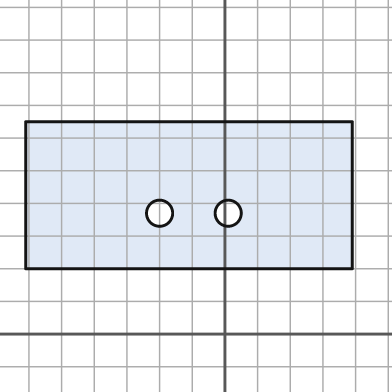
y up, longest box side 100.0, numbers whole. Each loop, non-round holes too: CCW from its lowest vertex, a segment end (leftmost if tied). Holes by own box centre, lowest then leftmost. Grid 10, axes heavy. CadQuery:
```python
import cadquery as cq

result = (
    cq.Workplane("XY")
    .moveTo(-61.0, 20.0)
    .lineTo(39.0, 20.0)
    .lineTo(39.0, 65.0)
    .lineTo(-61.0, 65.0)
    .close()
    .moveTo(-20.0, 37.0)
    .circle(4.0)
    .moveTo(1.0, 37.0)
    .circle(4.0)
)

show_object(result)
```